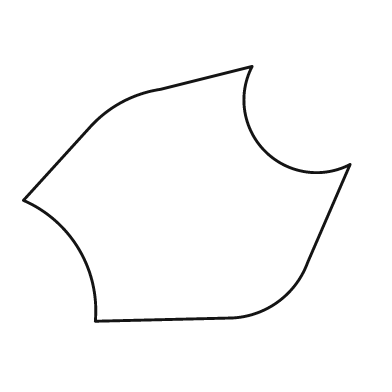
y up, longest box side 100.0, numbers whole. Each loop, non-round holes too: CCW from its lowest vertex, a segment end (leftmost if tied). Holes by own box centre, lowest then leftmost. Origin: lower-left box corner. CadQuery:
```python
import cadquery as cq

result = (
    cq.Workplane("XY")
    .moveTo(22.0, 0.0)
    .lineTo(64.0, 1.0)
    .threePointArc((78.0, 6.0), (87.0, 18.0))
    .lineTo(100.0, 48.0)
    .threePointArc((74.0, 52.0), (70.0, 78.0))
    .lineTo(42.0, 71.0)
    .threePointArc((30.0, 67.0), (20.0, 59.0))
    .lineTo(0.0, 37.0)
    .threePointArc((17.0, 22.0), (22.0, 0.0))
    .close()
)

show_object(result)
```